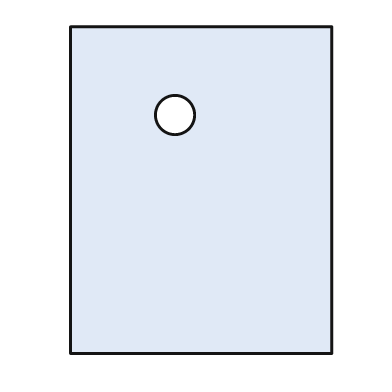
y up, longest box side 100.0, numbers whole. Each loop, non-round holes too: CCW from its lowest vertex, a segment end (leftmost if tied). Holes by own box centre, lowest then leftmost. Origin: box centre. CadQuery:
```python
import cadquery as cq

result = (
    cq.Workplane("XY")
    .moveTo(-40.0, -50.0)
    .lineTo(40.0, -50.0)
    .lineTo(40.0, 50.0)
    .lineTo(-40.0, 50.0)
    .close()
    .moveTo(-8.0, 23.0)
    .circle(6.0)
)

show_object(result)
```